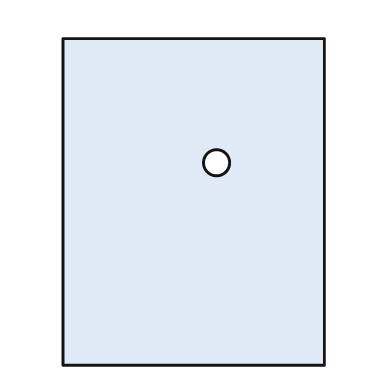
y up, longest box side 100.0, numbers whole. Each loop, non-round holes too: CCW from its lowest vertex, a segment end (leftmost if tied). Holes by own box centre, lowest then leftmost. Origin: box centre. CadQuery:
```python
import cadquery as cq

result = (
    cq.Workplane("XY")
    .moveTo(-40.0, -50.0)
    .lineTo(40.0, -50.0)
    .lineTo(40.0, 50.0)
    .lineTo(-40.0, 50.0)
    .close()
    .moveTo(7.0, 12.0)
    .circle(4.0)
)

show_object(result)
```